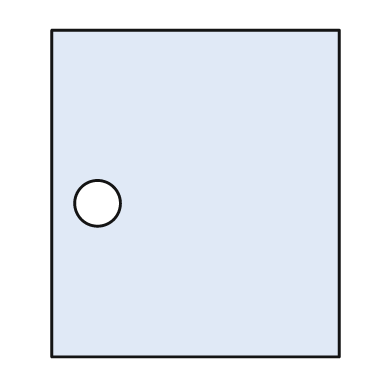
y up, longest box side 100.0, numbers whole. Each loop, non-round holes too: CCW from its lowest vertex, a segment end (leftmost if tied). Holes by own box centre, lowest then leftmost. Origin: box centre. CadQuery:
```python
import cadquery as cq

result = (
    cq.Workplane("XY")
    .moveTo(-44.0, -50.0)
    .lineTo(44.0, -50.0)
    .lineTo(44.0, 50.0)
    .lineTo(-44.0, 50.0)
    .close()
    .moveTo(-30.0, -3.0)
    .circle(7.0)
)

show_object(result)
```